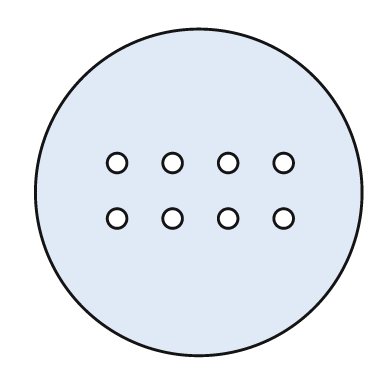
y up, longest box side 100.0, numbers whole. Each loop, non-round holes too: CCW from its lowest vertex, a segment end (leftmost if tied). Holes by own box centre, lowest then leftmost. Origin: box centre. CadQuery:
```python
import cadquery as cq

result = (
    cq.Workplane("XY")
    .moveTo(0.0, 0.0)
    .circle(50.0)
    .moveTo(-25.0, -8.0)
    .circle(3.0)
    .moveTo(-8.0, -8.0)
    .circle(3.0)
    .moveTo(9.0, -8.0)
    .circle(3.0)
    .moveTo(26.0, -8.0)
    .circle(3.0)
    .moveTo(-25.0, 9.0)
    .circle(3.0)
    .moveTo(-8.0, 9.0)
    .circle(3.0)
    .moveTo(9.0, 9.0)
    .circle(3.0)
    .moveTo(26.0, 9.0)
    .circle(3.0)
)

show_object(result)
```